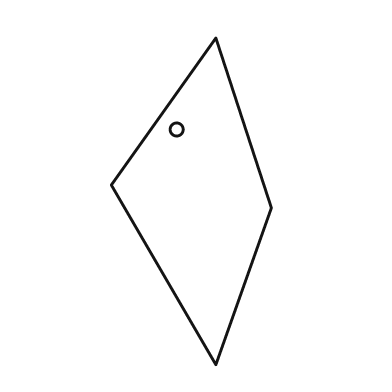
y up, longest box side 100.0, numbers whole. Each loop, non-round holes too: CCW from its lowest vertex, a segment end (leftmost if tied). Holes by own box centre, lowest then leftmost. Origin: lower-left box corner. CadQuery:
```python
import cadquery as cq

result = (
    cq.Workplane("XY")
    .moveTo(32.0, 0.0)
    .lineTo(49.0, 48.0)
    .lineTo(32.0, 100.0)
    .lineTo(0.0, 55.0)
    .close()
    .moveTo(20.0, 72.0)
    .circle(2.0)
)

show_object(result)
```